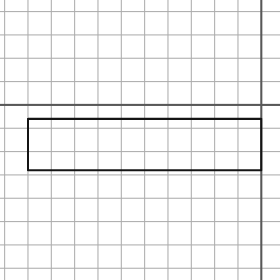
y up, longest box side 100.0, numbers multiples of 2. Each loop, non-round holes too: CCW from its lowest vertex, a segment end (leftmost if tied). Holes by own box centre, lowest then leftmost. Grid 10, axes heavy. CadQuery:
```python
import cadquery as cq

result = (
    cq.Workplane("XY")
    .moveTo(-100.0, -28.0)
    .lineTo(0.0, -28.0)
    .lineTo(0.0, -6.0)
    .lineTo(-100.0, -6.0)
    .close()
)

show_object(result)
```